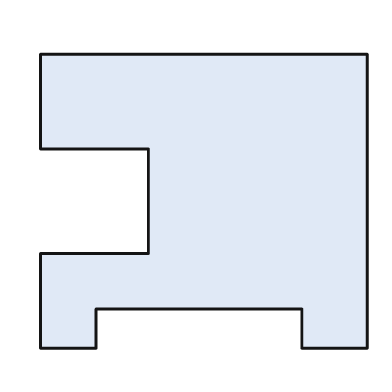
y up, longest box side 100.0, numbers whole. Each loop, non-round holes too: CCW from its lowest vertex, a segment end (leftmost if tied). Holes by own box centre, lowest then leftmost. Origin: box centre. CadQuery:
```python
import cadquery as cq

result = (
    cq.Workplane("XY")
    .moveTo(-50.0, -45.0)
    .lineTo(-33.0, -45.0)
    .lineTo(-33.0, -33.0)
    .lineTo(30.0, -33.0)
    .lineTo(30.0, -45.0)
    .lineTo(50.0, -45.0)
    .lineTo(50.0, 45.0)
    .lineTo(-50.0, 45.0)
    .lineTo(-50.0, 16.0)
    .lineTo(-17.0, 16.0)
    .lineTo(-17.0, -16.0)
    .lineTo(-50.0, -16.0)
    .close()
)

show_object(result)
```